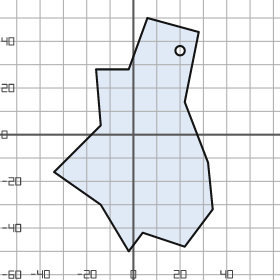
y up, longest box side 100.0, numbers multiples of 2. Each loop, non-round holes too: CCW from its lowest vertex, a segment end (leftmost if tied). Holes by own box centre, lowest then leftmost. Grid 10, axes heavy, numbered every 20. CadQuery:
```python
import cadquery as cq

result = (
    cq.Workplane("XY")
    .moveTo(-2.0, -50.0)
    .lineTo(4.0, -42.0)
    .lineTo(22.0, -48.0)
    .lineTo(34.0, -32.0)
    .lineTo(32.0, -12.0)
    .lineTo(22.0, 14.0)
    .lineTo(28.0, 44.0)
    .lineTo(6.0, 50.0)
    .lineTo(-2.0, 28.0)
    .lineTo(-16.0, 28.0)
    .lineTo(-14.0, 4.0)
    .lineTo(-34.0, -16.0)
    .lineTo(-14.0, -30.0)
    .close()
    .moveTo(20.0, 36.0)
    .circle(2.0)
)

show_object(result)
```